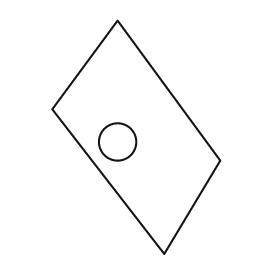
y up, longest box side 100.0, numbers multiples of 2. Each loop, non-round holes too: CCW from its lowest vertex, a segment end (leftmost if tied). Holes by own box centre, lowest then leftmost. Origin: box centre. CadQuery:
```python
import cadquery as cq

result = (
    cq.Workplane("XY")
    .moveTo(12.0, -50.0)
    .lineTo(36.0, -10.0)
    .lineTo(-8.0, 50.0)
    .lineTo(-36.0, 12.0)
    .close()
    .moveTo(-8.0, -2.0)
    .circle(8.0)
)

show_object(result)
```